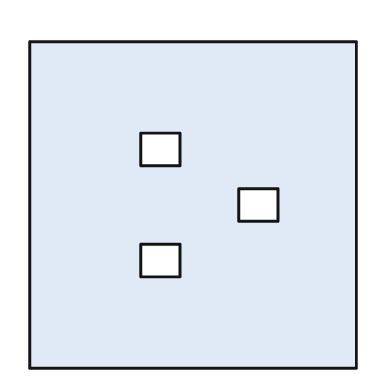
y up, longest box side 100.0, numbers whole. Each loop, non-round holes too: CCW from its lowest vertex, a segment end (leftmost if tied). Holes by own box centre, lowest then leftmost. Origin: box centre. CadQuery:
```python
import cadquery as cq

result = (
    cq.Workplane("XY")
    .moveTo(-50.0, -50.0)
    .lineTo(50.0, -50.0)
    .lineTo(50.0, 50.0)
    .lineTo(-50.0, 50.0)
    .close()
    .moveTo(-16.0, -22.0)
    .lineTo(-4.0, -22.0)
    .lineTo(-4.0, -12.0)
    .lineTo(-16.0, -12.0)
    .close()
    .moveTo(14.0, -5.0)
    .lineTo(26.0, -5.0)
    .lineTo(26.0, 5.0)
    .lineTo(14.0, 5.0)
    .close()
    .moveTo(-16.0, 12.0)
    .lineTo(-4.0, 12.0)
    .lineTo(-4.0, 22.0)
    .lineTo(-16.0, 22.0)
    .close()
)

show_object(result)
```